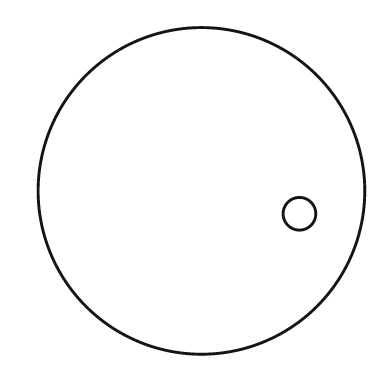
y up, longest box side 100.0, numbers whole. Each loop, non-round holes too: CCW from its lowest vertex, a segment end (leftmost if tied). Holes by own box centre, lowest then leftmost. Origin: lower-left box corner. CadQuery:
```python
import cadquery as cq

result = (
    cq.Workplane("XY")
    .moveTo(50.0, 50.0)
    .circle(50.0)
    .moveTo(80.0, 43.0)
    .circle(5.0)
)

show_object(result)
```